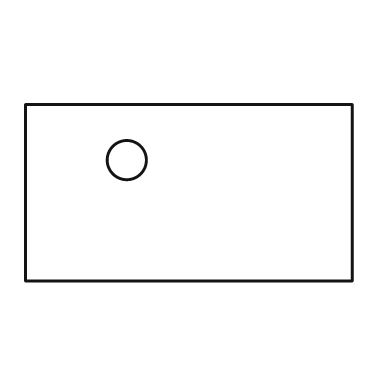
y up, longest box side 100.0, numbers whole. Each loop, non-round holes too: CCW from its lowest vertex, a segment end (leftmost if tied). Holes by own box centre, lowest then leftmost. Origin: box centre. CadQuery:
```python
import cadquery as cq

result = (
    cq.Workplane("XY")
    .moveTo(-50.0, -27.0)
    .lineTo(50.0, -27.0)
    .lineTo(50.0, 27.0)
    .lineTo(-50.0, 27.0)
    .close()
    .moveTo(-19.0, 10.0)
    .circle(6.0)
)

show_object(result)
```